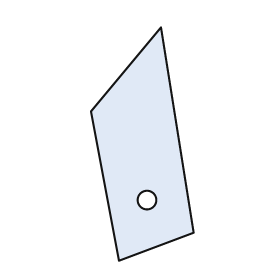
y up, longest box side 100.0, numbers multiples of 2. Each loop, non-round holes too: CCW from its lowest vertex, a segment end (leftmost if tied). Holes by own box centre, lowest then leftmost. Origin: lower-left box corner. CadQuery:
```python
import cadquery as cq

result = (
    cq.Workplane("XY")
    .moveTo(12.0, 0.0)
    .lineTo(44.0, 12.0)
    .lineTo(30.0, 100.0)
    .lineTo(0.0, 64.0)
    .close()
    .moveTo(24.0, 26.0)
    .circle(4.0)
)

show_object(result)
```